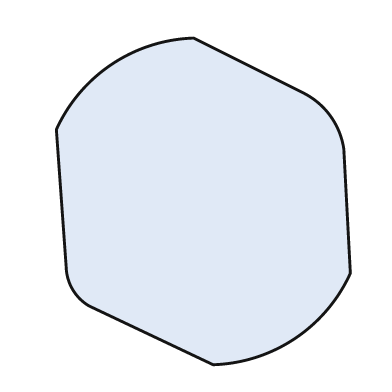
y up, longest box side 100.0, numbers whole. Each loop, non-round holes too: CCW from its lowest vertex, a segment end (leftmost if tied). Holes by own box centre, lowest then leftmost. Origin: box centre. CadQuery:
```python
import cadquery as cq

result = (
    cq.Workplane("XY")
    .moveTo(3.0, -50.0)
    .threePointArc((28.0, -42.0), (45.0, -22.0))
    .lineTo(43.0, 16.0)
    .threePointArc((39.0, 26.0), (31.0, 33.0))
    .lineTo(-3.0, 50.0)
    .threePointArc((-28.0, 42.0), (-45.0, 22.0))
    .lineTo(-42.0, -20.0)
    .threePointArc((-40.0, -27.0), (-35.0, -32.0))
    .close()
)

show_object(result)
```